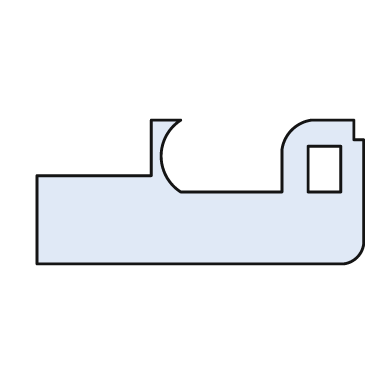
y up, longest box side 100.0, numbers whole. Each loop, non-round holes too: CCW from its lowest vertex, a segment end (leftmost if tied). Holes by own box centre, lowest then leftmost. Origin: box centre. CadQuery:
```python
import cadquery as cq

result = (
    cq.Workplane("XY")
    .moveTo(-50.0, -22.0)
    .lineTo(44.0, -22.0)
    .threePointArc((48.0, -20.0), (50.0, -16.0))
    .lineTo(50.0, 16.0)
    .lineTo(47.0, 16.0)
    .lineTo(47.0, 22.0)
    .lineTo(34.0, 22.0)
    .threePointArc((28.0, 19.0), (25.0, 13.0))
    .lineTo(25.0, 0.0)
    .lineTo(-6.0, 0.0)
    .threePointArc((-12.0, 11.0), (-6.0, 22.0))
    .lineTo(-15.0, 22.0)
    .lineTo(-15.0, 5.0)
    .lineTo(-50.0, 5.0)
    .close()
    .moveTo(33.0, 0.0)
    .lineTo(43.0, 0.0)
    .lineTo(43.0, 14.0)
    .lineTo(33.0, 14.0)
    .close()
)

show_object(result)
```